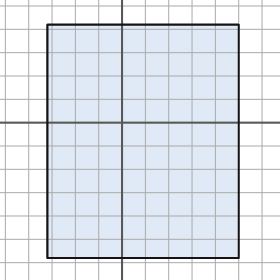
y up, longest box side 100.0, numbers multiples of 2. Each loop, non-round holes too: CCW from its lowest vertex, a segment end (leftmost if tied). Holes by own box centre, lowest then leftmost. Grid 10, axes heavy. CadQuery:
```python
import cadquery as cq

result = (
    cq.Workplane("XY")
    .moveTo(-32.0, -58.0)
    .lineTo(50.0, -58.0)
    .lineTo(50.0, 42.0)
    .lineTo(-32.0, 42.0)
    .close()
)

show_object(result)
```